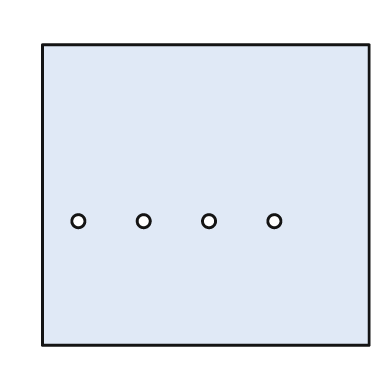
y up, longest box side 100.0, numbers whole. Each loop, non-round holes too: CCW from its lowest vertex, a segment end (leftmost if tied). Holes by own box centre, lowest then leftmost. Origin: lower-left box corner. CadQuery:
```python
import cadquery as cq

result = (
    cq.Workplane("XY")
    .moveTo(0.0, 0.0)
    .lineTo(100.0, 0.0)
    .lineTo(100.0, 92.0)
    .lineTo(0.0, 92.0)
    .close()
    .moveTo(11.0, 38.0)
    .circle(2.0)
    .moveTo(31.0, 38.0)
    .circle(2.0)
    .moveTo(51.0, 38.0)
    .circle(2.0)
    .moveTo(71.0, 38.0)
    .circle(2.0)
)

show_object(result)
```